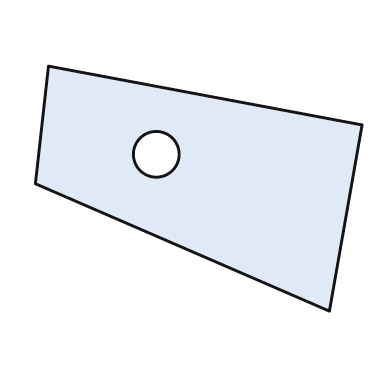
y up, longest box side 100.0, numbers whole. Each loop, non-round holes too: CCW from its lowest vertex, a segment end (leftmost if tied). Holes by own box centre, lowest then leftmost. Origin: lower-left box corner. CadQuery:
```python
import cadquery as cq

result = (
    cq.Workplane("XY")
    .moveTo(90.0, 0.0)
    .lineTo(100.0, 57.0)
    .lineTo(4.0, 75.0)
    .lineTo(0.0, 39.0)
    .close()
    .moveTo(37.0, 48.0)
    .circle(7.0)
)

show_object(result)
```